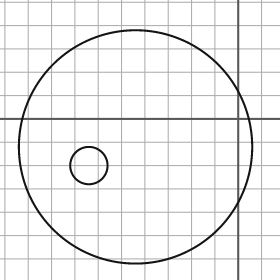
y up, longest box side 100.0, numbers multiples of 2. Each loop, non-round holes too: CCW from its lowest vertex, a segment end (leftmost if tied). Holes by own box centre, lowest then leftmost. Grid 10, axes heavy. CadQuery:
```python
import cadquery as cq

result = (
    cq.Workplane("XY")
    .moveTo(-44.0, -12.0)
    .circle(50.0)
    .moveTo(-64.0, -20.0)
    .circle(8.0)
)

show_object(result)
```